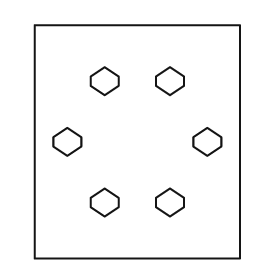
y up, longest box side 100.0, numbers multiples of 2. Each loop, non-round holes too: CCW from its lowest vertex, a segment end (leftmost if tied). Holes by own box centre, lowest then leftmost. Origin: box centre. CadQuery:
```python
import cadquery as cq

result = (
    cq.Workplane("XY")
    .moveTo(-44.0, -50.0)
    .lineTo(44.0, -50.0)
    .lineTo(44.0, 50.0)
    .lineTo(-44.0, 50.0)
    .close()
    .moveTo(-14.0, -32.0)
    .lineTo(-8.0, -28.0)
    .lineTo(-8.0, -24.0)
    .lineTo(-14.0, -20.0)
    .lineTo(-20.0, -24.0)
    .lineTo(-20.0, -28.0)
    .close()
    .moveTo(14.0, -32.0)
    .lineTo(20.0, -28.0)
    .lineTo(20.0, -24.0)
    .lineTo(14.0, -20.0)
    .lineTo(8.0, -24.0)
    .lineTo(8.0, -28.0)
    .close()
    .moveTo(-30.0, -6.0)
    .lineTo(-24.0, -2.0)
    .lineTo(-24.0, 2.0)
    .lineTo(-30.0, 6.0)
    .lineTo(-36.0, 2.0)
    .lineTo(-36.0, -2.0)
    .close()
    .moveTo(30.0, -6.0)
    .lineTo(36.0, -2.0)
    .lineTo(36.0, 2.0)
    .lineTo(30.0, 6.0)
    .lineTo(24.0, 2.0)
    .lineTo(24.0, -2.0)
    .close()
    .moveTo(-14.0, 20.0)
    .lineTo(-8.0, 24.0)
    .lineTo(-8.0, 28.0)
    .lineTo(-14.0, 32.0)
    .lineTo(-20.0, 28.0)
    .lineTo(-20.0, 24.0)
    .close()
    .moveTo(14.0, 20.0)
    .lineTo(20.0, 24.0)
    .lineTo(20.0, 28.0)
    .lineTo(14.0, 32.0)
    .lineTo(8.0, 28.0)
    .lineTo(8.0, 24.0)
    .close()
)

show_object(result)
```